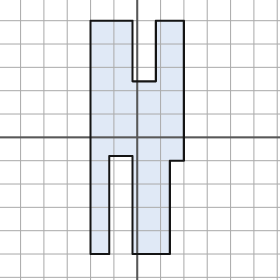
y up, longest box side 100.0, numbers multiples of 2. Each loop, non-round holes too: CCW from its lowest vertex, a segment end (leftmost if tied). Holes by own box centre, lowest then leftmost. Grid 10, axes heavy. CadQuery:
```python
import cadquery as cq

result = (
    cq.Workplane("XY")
    .moveTo(-20.0, -50.0)
    .lineTo(-12.0, -50.0)
    .lineTo(-12.0, -8.0)
    .lineTo(-2.0, -8.0)
    .lineTo(-2.0, -50.0)
    .lineTo(14.0, -50.0)
    .lineTo(14.0, -10.0)
    .lineTo(20.0, -10.0)
    .lineTo(20.0, 50.0)
    .lineTo(8.0, 50.0)
    .lineTo(8.0, 24.0)
    .lineTo(-2.0, 24.0)
    .lineTo(-2.0, 50.0)
    .lineTo(-20.0, 50.0)
    .close()
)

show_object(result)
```